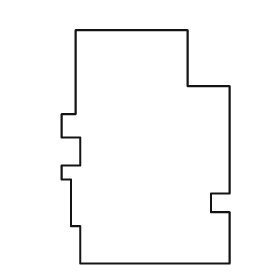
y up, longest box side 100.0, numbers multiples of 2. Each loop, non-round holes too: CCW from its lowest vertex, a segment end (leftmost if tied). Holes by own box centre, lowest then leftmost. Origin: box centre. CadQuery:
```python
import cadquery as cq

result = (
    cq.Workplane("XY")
    .moveTo(-28.0, -50.0)
    .lineTo(36.0, -50.0)
    .lineTo(36.0, -28.0)
    .lineTo(28.0, -28.0)
    .lineTo(28.0, -20.0)
    .lineTo(36.0, -20.0)
    .lineTo(36.0, 26.0)
    .lineTo(18.0, 26.0)
    .lineTo(18.0, 50.0)
    .lineTo(-30.0, 50.0)
    .lineTo(-30.0, 14.0)
    .lineTo(-36.0, 14.0)
    .lineTo(-36.0, 4.0)
    .lineTo(-28.0, 4.0)
    .lineTo(-28.0, -8.0)
    .lineTo(-36.0, -8.0)
    .lineTo(-36.0, -14.0)
    .lineTo(-32.0, -14.0)
    .lineTo(-32.0, -34.0)
    .lineTo(-28.0, -34.0)
    .close()
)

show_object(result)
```